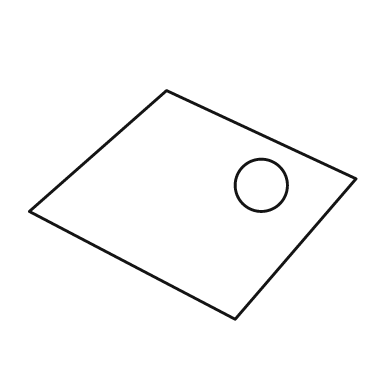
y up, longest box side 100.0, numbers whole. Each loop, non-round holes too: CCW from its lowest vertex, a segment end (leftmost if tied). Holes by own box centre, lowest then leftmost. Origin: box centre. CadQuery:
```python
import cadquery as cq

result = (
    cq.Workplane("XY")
    .moveTo(13.0, -35.0)
    .lineTo(50.0, 8.0)
    .lineTo(-8.0, 35.0)
    .lineTo(-50.0, -2.0)
    .close()
    .moveTo(21.0, 6.0)
    .circle(8.0)
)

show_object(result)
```